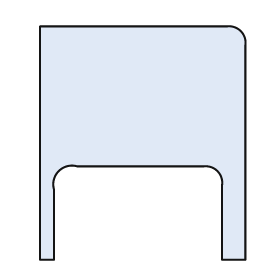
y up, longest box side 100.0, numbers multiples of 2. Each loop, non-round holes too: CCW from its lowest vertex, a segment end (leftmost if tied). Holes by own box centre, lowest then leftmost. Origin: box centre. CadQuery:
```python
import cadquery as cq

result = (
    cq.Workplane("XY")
    .moveTo(-44.0, -50.0)
    .lineTo(-38.0, -50.0)
    .lineTo(-38.0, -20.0)
    .threePointArc((-36.0, -12.0), (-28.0, -10.0))
    .lineTo(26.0, -10.0)
    .threePointArc((32.0, -12.0), (34.0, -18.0))
    .lineTo(34.0, -50.0)
    .lineTo(44.0, -50.0)
    .lineTo(44.0, 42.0)
    .threePointArc((42.0, 48.0), (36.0, 50.0))
    .lineTo(-44.0, 50.0)
    .close()
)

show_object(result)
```